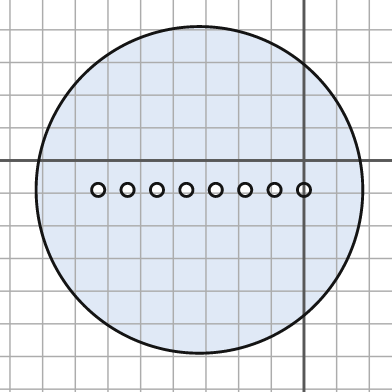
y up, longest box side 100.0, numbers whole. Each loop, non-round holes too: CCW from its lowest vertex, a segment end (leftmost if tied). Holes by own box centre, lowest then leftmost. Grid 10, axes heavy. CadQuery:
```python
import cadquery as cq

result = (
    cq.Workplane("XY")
    .moveTo(-32.0, -9.0)
    .circle(50.0)
    .moveTo(-63.0, -9.0)
    .circle(2.0)
    .moveTo(-54.0, -9.0)
    .circle(2.0)
    .moveTo(-45.0, -9.0)
    .circle(2.0)
    .moveTo(-36.0, -9.0)
    .circle(2.0)
    .moveTo(-27.0, -9.0)
    .circle(2.0)
    .moveTo(-18.0, -9.0)
    .circle(2.0)
    .moveTo(-9.0, -9.0)
    .circle(2.0)
    .moveTo(0.0, -9.0)
    .circle(2.0)
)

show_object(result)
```